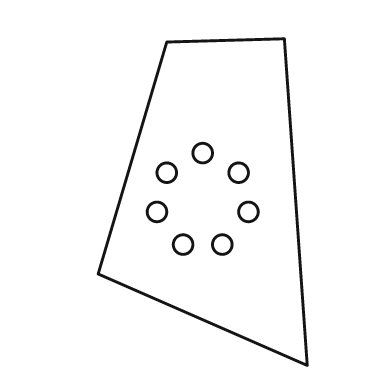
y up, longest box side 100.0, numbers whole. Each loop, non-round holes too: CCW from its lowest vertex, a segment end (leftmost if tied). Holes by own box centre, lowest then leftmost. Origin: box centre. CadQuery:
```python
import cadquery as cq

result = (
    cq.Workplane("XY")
    .moveTo(32.0, -50.0)
    .lineTo(25.0, 50.0)
    .lineTo(-11.0, 49.0)
    .lineTo(-32.0, -22.0)
    .close()
    .moveTo(-6.0, -13.0)
    .circle(3.0)
    .moveTo(6.0, -13.0)
    .circle(3.0)
    .moveTo(-14.0, -3.0)
    .circle(3.0)
    .moveTo(14.0, -3.0)
    .circle(3.0)
    .moveTo(-11.0, 9.0)
    .circle(3.0)
    .moveTo(11.0, 9.0)
    .circle(3.0)
    .moveTo(0.0, 15.0)
    .circle(3.0)
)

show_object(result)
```